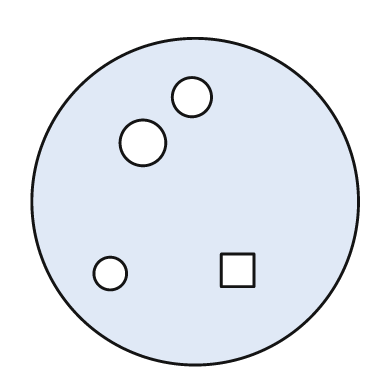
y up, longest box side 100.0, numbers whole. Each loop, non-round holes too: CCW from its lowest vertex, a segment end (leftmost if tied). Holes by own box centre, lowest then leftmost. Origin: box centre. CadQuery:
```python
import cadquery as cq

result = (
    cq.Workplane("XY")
    .moveTo(0.0, 0.0)
    .circle(50.0)
    .moveTo(-26.0, -22.0)
    .circle(5.0)
    .moveTo(8.0, -26.0)
    .lineTo(18.0, -26.0)
    .lineTo(18.0, -16.0)
    .lineTo(8.0, -16.0)
    .close()
    .moveTo(-16.0, 18.0)
    .circle(7.0)
    .moveTo(-1.0, 32.0)
    .circle(6.0)
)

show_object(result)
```